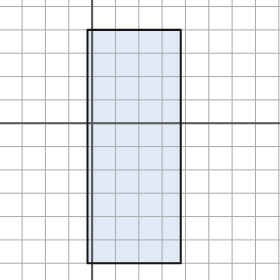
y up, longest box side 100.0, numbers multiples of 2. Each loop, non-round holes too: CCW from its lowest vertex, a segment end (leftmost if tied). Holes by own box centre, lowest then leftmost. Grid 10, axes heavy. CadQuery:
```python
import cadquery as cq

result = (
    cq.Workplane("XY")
    .moveTo(-2.0, -60.0)
    .lineTo(38.0, -60.0)
    .lineTo(38.0, 40.0)
    .lineTo(-2.0, 40.0)
    .close()
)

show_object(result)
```